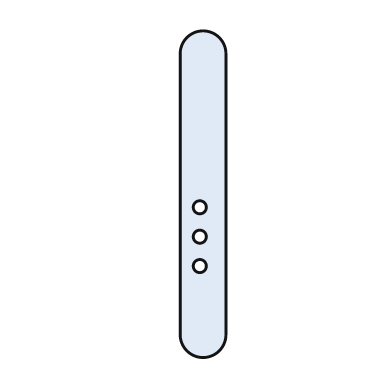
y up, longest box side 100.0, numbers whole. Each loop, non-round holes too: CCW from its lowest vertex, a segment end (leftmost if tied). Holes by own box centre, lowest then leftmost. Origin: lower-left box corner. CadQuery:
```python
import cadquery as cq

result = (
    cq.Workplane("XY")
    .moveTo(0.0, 7.0)
    .threePointArc((7.0, 0.0), (14.0, 7.0))
    .lineTo(14.0, 93.0)
    .threePointArc((7.0, 100.0), (0.0, 93.0))
    .close()
    .moveTo(6.0, 28.0)
    .circle(2.0)
    .moveTo(6.0, 37.0)
    .circle(2.0)
    .moveTo(6.0, 46.0)
    .circle(2.0)
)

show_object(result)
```